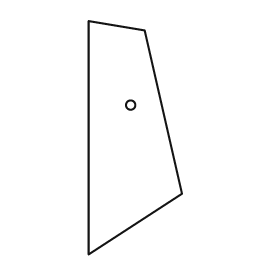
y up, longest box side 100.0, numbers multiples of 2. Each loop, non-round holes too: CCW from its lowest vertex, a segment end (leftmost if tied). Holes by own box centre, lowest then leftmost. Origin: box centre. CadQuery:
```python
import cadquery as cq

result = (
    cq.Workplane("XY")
    .moveTo(-20.0, -50.0)
    .lineTo(20.0, -24.0)
    .lineTo(4.0, 46.0)
    .lineTo(-20.0, 50.0)
    .close()
    .moveTo(-2.0, 14.0)
    .circle(2.0)
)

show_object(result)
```